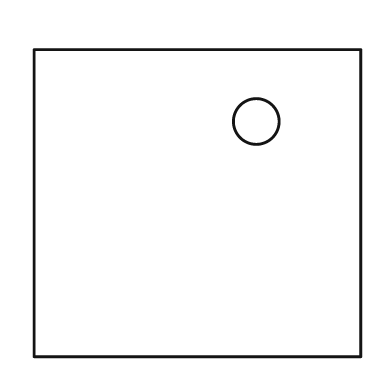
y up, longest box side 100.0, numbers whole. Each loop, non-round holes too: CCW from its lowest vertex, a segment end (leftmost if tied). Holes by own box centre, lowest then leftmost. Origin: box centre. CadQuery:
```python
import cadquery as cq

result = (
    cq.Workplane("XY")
    .moveTo(-50.0, -47.0)
    .lineTo(50.0, -47.0)
    .lineTo(50.0, 47.0)
    .lineTo(-50.0, 47.0)
    .close()
    .moveTo(18.0, 25.0)
    .circle(7.0)
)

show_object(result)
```